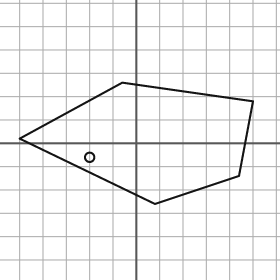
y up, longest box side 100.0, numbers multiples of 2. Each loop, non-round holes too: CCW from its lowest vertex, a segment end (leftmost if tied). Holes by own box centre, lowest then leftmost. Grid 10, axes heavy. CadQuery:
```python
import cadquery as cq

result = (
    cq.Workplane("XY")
    .moveTo(8.0, -26.0)
    .lineTo(44.0, -14.0)
    .lineTo(50.0, 18.0)
    .lineTo(-6.0, 26.0)
    .lineTo(-50.0, 2.0)
    .close()
    .moveTo(-20.0, -6.0)
    .circle(2.0)
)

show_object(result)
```